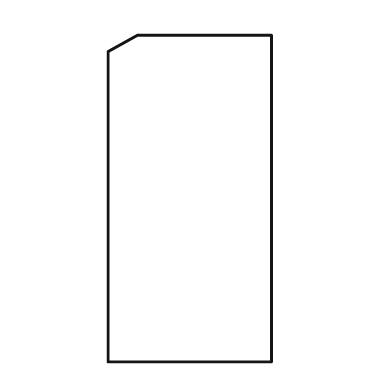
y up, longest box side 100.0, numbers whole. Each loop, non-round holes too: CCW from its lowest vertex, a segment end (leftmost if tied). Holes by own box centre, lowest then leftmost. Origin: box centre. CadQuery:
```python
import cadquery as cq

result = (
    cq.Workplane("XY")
    .moveTo(-25.0, -50.0)
    .lineTo(25.0, -50.0)
    .lineTo(25.0, 50.0)
    .lineTo(-16.0, 50.0)
    .lineTo(-25.0, 45.0)
    .close()
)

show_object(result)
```